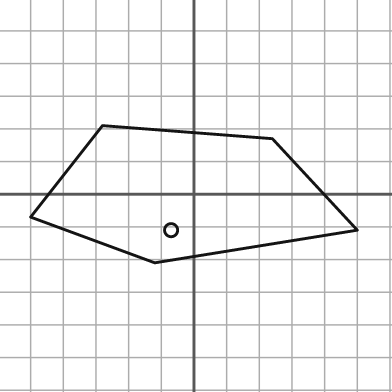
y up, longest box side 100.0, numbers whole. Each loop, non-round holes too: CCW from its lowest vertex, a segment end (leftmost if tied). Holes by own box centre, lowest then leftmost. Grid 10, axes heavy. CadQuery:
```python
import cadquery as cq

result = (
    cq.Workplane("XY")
    .moveTo(-12.0, -21.0)
    .lineTo(50.0, -11.0)
    .lineTo(24.0, 17.0)
    .lineTo(-28.0, 21.0)
    .lineTo(-50.0, -7.0)
    .close()
    .moveTo(-7.0, -11.0)
    .circle(2.0)
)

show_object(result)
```